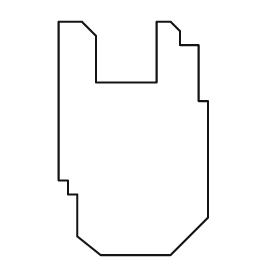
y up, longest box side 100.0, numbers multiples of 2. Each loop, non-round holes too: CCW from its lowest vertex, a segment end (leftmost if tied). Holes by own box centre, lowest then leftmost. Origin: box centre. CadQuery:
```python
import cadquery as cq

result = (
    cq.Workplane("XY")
    .moveTo(-14.0, -50.0)
    .lineTo(16.0, -50.0)
    .lineTo(32.0, -34.0)
    .lineTo(32.0, 16.0)
    .lineTo(28.0, 16.0)
    .lineTo(28.0, 40.0)
    .lineTo(20.0, 40.0)
    .lineTo(20.0, 46.0)
    .lineTo(16.0, 50.0)
    .lineTo(10.0, 50.0)
    .lineTo(10.0, 24.0)
    .lineTo(-16.0, 24.0)
    .lineTo(-16.0, 44.0)
    .lineTo(-22.0, 50.0)
    .lineTo(-32.0, 50.0)
    .lineTo(-32.0, -18.0)
    .lineTo(-28.0, -18.0)
    .lineTo(-28.0, -24.0)
    .lineTo(-24.0, -24.0)
    .lineTo(-24.0, -42.0)
    .close()
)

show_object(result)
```